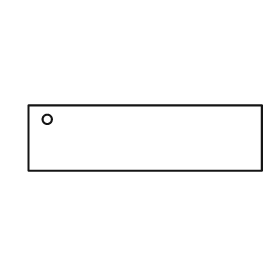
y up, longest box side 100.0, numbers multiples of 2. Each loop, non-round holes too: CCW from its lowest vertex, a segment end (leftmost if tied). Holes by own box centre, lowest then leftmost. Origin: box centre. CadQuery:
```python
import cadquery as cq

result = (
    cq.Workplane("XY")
    .moveTo(-50.0, -14.0)
    .lineTo(50.0, -14.0)
    .lineTo(50.0, 14.0)
    .lineTo(-50.0, 14.0)
    .close()
    .moveTo(-42.0, 8.0)
    .circle(2.0)
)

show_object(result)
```